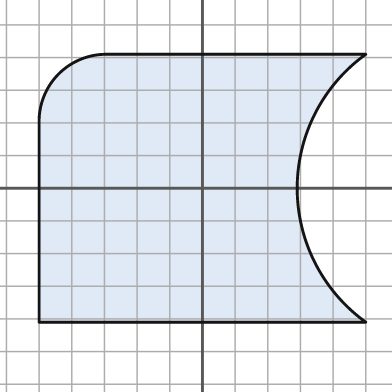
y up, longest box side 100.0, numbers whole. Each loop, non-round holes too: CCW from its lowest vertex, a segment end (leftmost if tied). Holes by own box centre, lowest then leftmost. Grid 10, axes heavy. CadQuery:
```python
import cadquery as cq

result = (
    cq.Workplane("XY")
    .moveTo(-50.0, -41.0)
    .lineTo(50.0, -41.0)
    .threePointArc((29.0, 0.0), (50.0, 41.0))
    .lineTo(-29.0, 41.0)
    .threePointArc((-44.0, 35.0), (-50.0, 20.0))
    .close()
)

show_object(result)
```